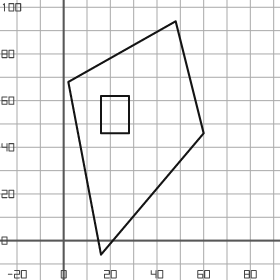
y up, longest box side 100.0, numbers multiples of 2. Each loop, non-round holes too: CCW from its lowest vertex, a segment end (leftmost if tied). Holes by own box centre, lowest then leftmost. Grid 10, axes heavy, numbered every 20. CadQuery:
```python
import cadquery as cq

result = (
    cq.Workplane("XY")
    .moveTo(16.0, -6.0)
    .lineTo(60.0, 46.0)
    .lineTo(48.0, 94.0)
    .lineTo(2.0, 68.0)
    .close()
    .moveTo(16.0, 46.0)
    .lineTo(28.0, 46.0)
    .lineTo(28.0, 62.0)
    .lineTo(16.0, 62.0)
    .close()
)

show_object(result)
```